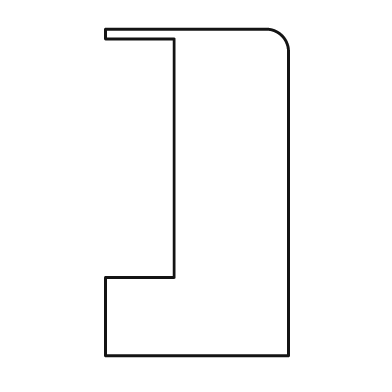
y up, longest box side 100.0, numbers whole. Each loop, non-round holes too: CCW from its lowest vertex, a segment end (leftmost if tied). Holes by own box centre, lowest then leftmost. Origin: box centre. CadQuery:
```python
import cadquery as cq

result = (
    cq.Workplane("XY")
    .moveTo(-28.0, -50.0)
    .lineTo(28.0, -50.0)
    .lineTo(28.0, 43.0)
    .threePointArc((26.0, 48.0), (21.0, 50.0))
    .lineTo(-28.0, 50.0)
    .lineTo(-28.0, 47.0)
    .lineTo(-7.0, 47.0)
    .lineTo(-7.0, -26.0)
    .lineTo(-28.0, -26.0)
    .close()
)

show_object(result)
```